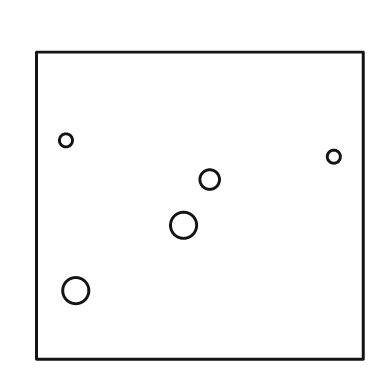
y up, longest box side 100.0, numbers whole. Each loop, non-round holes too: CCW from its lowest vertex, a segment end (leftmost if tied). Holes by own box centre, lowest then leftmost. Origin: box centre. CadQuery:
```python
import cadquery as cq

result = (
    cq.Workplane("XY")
    .moveTo(-50.0, -47.0)
    .lineTo(50.0, -47.0)
    .lineTo(50.0, 47.0)
    .lineTo(-50.0, 47.0)
    .close()
    .moveTo(-38.0, -26.0)
    .circle(4.0)
    .moveTo(-5.0, -6.0)
    .circle(4.0)
    .moveTo(3.0, 8.0)
    .circle(3.0)
    .moveTo(41.0, 15.0)
    .circle(2.0)
    .moveTo(-41.0, 20.0)
    .circle(2.0)
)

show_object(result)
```